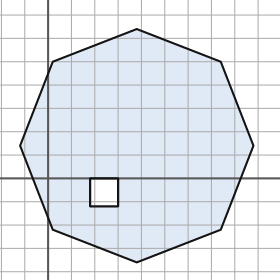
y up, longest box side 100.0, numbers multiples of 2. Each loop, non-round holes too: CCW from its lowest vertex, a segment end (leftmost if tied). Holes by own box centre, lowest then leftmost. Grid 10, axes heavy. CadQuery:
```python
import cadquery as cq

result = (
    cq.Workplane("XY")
    .moveTo(38.0, -36.0)
    .lineTo(74.0, -22.0)
    .lineTo(88.0, 14.0)
    .lineTo(74.0, 50.0)
    .lineTo(38.0, 64.0)
    .lineTo(2.0, 50.0)
    .lineTo(-12.0, 14.0)
    .lineTo(2.0, -22.0)
    .close()
    .moveTo(18.0, -12.0)
    .lineTo(30.0, -12.0)
    .lineTo(30.0, 0.0)
    .lineTo(18.0, 0.0)
    .close()
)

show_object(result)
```